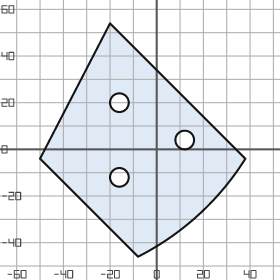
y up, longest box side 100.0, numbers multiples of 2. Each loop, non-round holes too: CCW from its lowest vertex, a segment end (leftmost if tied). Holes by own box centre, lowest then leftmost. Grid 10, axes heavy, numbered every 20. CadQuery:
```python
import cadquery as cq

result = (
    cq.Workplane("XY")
    .moveTo(-8.0, -46.0)
    .threePointArc((18.0, -28.0), (38.0, -4.0))
    .lineTo(-20.0, 54.0)
    .lineTo(-50.0, -4.0)
    .close()
    .moveTo(-16.0, -12.0)
    .circle(4.0)
    .moveTo(12.0, 4.0)
    .circle(4.0)
    .moveTo(-16.0, 20.0)
    .circle(4.0)
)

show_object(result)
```